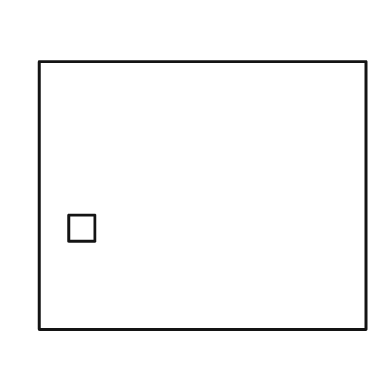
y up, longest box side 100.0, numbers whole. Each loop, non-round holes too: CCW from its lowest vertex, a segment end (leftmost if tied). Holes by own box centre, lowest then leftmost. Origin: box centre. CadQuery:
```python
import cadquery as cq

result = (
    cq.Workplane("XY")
    .moveTo(-50.0, -41.0)
    .lineTo(50.0, -41.0)
    .lineTo(50.0, 41.0)
    .lineTo(-50.0, 41.0)
    .close()
    .moveTo(-41.0, -14.0)
    .lineTo(-33.0, -14.0)
    .lineTo(-33.0, -6.0)
    .lineTo(-41.0, -6.0)
    .close()
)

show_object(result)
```